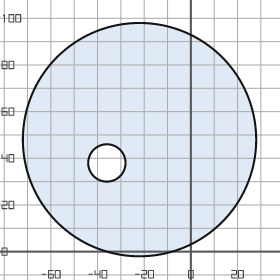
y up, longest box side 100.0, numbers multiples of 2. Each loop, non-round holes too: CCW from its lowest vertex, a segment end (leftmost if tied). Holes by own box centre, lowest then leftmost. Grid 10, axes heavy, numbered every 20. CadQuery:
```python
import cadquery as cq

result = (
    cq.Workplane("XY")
    .moveTo(-22.0, 48.0)
    .circle(50.0)
    .moveTo(-36.0, 38.0)
    .circle(8.0)
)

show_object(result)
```